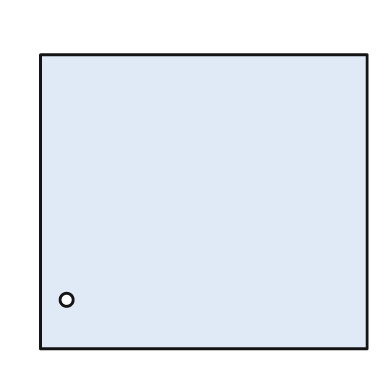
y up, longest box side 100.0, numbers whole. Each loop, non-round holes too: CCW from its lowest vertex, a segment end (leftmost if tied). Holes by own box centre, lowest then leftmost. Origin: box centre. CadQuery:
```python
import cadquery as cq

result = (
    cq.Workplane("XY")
    .moveTo(-50.0, -45.0)
    .lineTo(50.0, -45.0)
    .lineTo(50.0, 45.0)
    .lineTo(-50.0, 45.0)
    .close()
    .moveTo(-42.0, -30.0)
    .circle(2.0)
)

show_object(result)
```